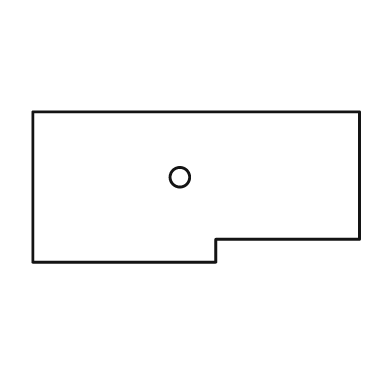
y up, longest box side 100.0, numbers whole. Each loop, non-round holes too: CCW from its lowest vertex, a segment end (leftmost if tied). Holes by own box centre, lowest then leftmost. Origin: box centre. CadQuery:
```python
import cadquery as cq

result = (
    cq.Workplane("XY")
    .moveTo(-50.0, -23.0)
    .lineTo(6.0, -23.0)
    .lineTo(6.0, -16.0)
    .lineTo(50.0, -16.0)
    .lineTo(50.0, 23.0)
    .lineTo(-50.0, 23.0)
    .close()
    .moveTo(-5.0, 3.0)
    .circle(3.0)
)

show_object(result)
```